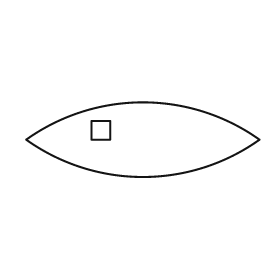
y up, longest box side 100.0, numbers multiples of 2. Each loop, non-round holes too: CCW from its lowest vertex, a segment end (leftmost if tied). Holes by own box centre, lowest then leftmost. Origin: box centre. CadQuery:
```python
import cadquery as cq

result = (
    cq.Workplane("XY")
    .moveTo(-50.0, 0.0)
    .threePointArc((0.0, -16.0), (50.0, 0.0))
    .threePointArc((0.0, 16.0), (-50.0, 0.0))
    .close()
    .moveTo(-22.0, 0.0)
    .lineTo(-14.0, 0.0)
    .lineTo(-14.0, 8.0)
    .lineTo(-22.0, 8.0)
    .close()
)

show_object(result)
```